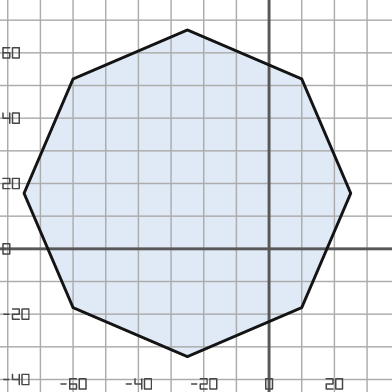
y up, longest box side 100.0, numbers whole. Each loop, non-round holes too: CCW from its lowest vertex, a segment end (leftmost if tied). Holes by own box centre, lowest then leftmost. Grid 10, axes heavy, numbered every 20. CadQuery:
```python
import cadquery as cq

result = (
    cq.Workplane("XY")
    .moveTo(-25.0, -33.0)
    .lineTo(10.0, -18.0)
    .lineTo(25.0, 17.0)
    .lineTo(10.0, 52.0)
    .lineTo(-25.0, 67.0)
    .lineTo(-60.0, 52.0)
    .lineTo(-75.0, 17.0)
    .lineTo(-60.0, -18.0)
    .close()
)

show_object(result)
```